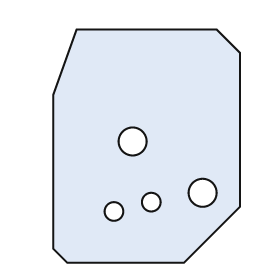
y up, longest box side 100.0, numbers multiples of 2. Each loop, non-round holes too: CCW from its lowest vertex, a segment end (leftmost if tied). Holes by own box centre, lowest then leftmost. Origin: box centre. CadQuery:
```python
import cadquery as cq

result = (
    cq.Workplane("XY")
    .moveTo(-34.0, -50.0)
    .lineTo(16.0, -50.0)
    .lineTo(40.0, -26.0)
    .lineTo(40.0, 40.0)
    .lineTo(30.0, 50.0)
    .lineTo(-30.0, 50.0)
    .lineTo(-40.0, 22.0)
    .lineTo(-40.0, -44.0)
    .close()
    .moveTo(-14.0, -28.0)
    .circle(4.0)
    .moveTo(2.0, -24.0)
    .circle(4.0)
    .moveTo(24.0, -20.0)
    .circle(6.0)
    .moveTo(-6.0, 2.0)
    .circle(6.0)
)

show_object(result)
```